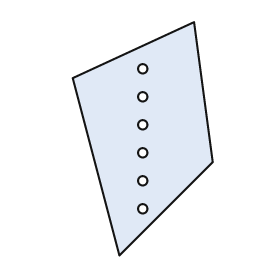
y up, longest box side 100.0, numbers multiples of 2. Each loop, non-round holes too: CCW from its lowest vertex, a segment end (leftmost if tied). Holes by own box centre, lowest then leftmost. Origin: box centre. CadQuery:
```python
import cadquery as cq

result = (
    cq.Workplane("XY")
    .moveTo(-10.0, -50.0)
    .lineTo(30.0, -10.0)
    .lineTo(22.0, 50.0)
    .lineTo(-30.0, 26.0)
    .close()
    .moveTo(0.0, -30.0)
    .circle(2.0)
    .moveTo(0.0, -18.0)
    .circle(2.0)
    .moveTo(0.0, -6.0)
    .circle(2.0)
    .moveTo(0.0, 6.0)
    .circle(2.0)
    .moveTo(0.0, 18.0)
    .circle(2.0)
    .moveTo(0.0, 30.0)
    .circle(2.0)
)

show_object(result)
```